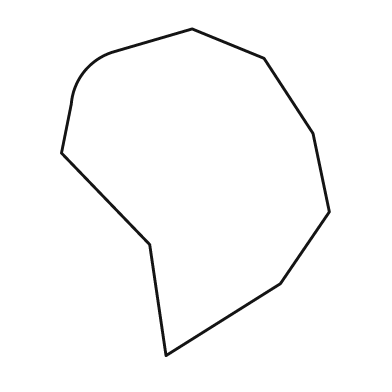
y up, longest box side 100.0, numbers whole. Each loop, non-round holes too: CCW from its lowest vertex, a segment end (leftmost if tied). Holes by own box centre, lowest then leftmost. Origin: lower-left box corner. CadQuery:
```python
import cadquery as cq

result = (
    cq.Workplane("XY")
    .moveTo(32.0, 0.0)
    .lineTo(67.0, 22.0)
    .lineTo(82.0, 44.0)
    .lineTo(77.0, 68.0)
    .lineTo(62.0, 91.0)
    .lineTo(40.0, 100.0)
    .lineTo(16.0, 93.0)
    .threePointArc((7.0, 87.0), (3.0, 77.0))
    .lineTo(0.0, 62.0)
    .lineTo(27.0, 34.0)
    .close()
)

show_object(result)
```